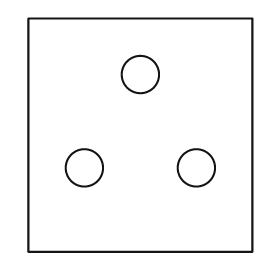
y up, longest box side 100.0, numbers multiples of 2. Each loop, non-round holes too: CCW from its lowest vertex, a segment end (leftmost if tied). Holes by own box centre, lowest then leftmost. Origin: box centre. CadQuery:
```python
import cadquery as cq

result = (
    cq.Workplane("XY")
    .moveTo(-48.0, -50.0)
    .lineTo(48.0, -50.0)
    .lineTo(48.0, 50.0)
    .lineTo(-48.0, 50.0)
    .close()
    .moveTo(-24.0, -14.0)
    .circle(8.0)
    .moveTo(24.0, -14.0)
    .circle(8.0)
    .moveTo(0.0, 26.0)
    .circle(8.0)
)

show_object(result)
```